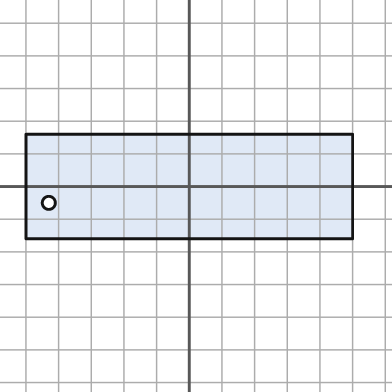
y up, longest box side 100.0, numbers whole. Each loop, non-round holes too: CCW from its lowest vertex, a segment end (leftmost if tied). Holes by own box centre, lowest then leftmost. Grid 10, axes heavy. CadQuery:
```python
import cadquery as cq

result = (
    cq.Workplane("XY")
    .moveTo(-50.0, -16.0)
    .lineTo(50.0, -16.0)
    .lineTo(50.0, 16.0)
    .lineTo(-50.0, 16.0)
    .close()
    .moveTo(-43.0, -5.0)
    .circle(2.0)
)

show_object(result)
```